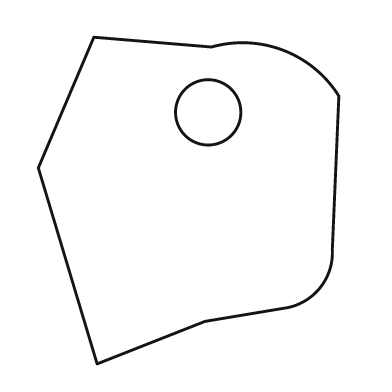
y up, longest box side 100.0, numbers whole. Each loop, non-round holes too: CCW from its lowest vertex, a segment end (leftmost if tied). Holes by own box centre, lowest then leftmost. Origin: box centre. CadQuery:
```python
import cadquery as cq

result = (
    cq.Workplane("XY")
    .moveTo(-28.0, -50.0)
    .lineTo(5.0, -37.0)
    .lineTo(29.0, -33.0)
    .threePointArc((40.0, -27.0), (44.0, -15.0))
    .lineTo(46.0, 32.0)
    .threePointArc((29.0, 46.0), (7.0, 47.0))
    .lineTo(-29.0, 50.0)
    .lineTo(-46.0, 10.0)
    .close()
    .moveTo(6.0, 27.0)
    .circle(10.0)
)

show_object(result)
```